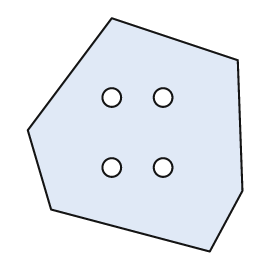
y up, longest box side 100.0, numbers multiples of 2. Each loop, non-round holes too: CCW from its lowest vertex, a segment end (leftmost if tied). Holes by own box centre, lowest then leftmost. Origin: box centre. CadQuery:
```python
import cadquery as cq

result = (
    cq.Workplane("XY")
    .moveTo(32.0, -50.0)
    .lineTo(46.0, -24.0)
    .lineTo(44.0, 32.0)
    .lineTo(-10.0, 50.0)
    .lineTo(-46.0, 2.0)
    .lineTo(-36.0, -32.0)
    .close()
    .moveTo(-10.0, -14.0)
    .circle(4.0)
    .moveTo(12.0, -14.0)
    .circle(4.0)
    .moveTo(-10.0, 16.0)
    .circle(4.0)
    .moveTo(12.0, 16.0)
    .circle(4.0)
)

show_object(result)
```